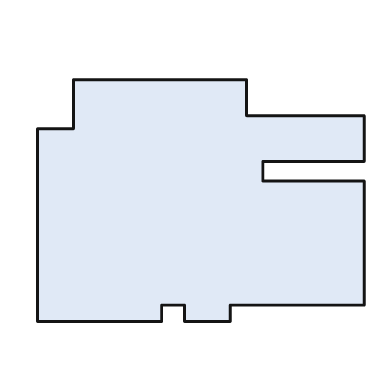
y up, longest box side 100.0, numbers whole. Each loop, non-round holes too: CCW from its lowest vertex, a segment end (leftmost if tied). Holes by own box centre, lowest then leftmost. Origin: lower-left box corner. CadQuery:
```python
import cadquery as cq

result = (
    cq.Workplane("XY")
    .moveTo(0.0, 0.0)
    .lineTo(38.0, 0.0)
    .lineTo(38.0, 5.0)
    .lineTo(45.0, 5.0)
    .lineTo(45.0, 0.0)
    .lineTo(59.0, 0.0)
    .lineTo(59.0, 5.0)
    .lineTo(100.0, 5.0)
    .lineTo(100.0, 43.0)
    .lineTo(69.0, 43.0)
    .lineTo(69.0, 49.0)
    .lineTo(100.0, 49.0)
    .lineTo(100.0, 63.0)
    .lineTo(64.0, 63.0)
    .lineTo(64.0, 74.0)
    .lineTo(11.0, 74.0)
    .lineTo(11.0, 59.0)
    .lineTo(0.0, 59.0)
    .close()
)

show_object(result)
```